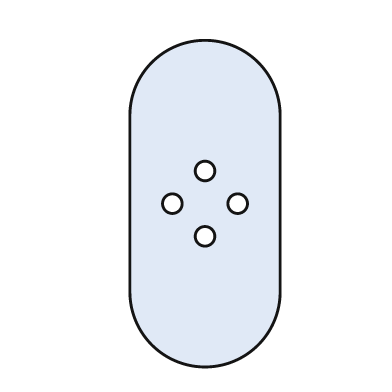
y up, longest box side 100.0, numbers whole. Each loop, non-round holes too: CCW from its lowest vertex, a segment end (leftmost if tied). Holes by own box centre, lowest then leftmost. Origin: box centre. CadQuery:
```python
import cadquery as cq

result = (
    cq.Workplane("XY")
    .moveTo(-23.0, -27.0)
    .threePointArc((0.0, -50.0), (23.0, -27.0))
    .lineTo(23.0, 27.0)
    .threePointArc((0.0, 50.0), (-23.0, 27.0))
    .close()
    .moveTo(0.0, -10.0)
    .circle(3.0)
    .moveTo(-10.0, 0.0)
    .circle(3.0)
    .moveTo(10.0, 0.0)
    .circle(3.0)
    .moveTo(0.0, 10.0)
    .circle(3.0)
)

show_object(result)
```